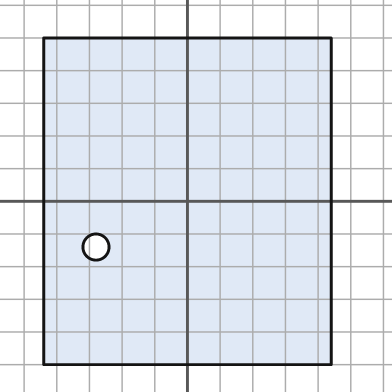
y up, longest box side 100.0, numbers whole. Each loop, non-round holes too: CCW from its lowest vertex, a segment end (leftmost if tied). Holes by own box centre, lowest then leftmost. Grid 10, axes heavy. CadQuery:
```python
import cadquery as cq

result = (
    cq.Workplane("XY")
    .moveTo(-44.0, -50.0)
    .lineTo(44.0, -50.0)
    .lineTo(44.0, 50.0)
    .lineTo(-44.0, 50.0)
    .close()
    .moveTo(-28.0, -14.0)
    .circle(4.0)
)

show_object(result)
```